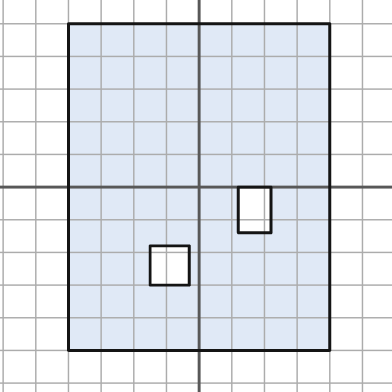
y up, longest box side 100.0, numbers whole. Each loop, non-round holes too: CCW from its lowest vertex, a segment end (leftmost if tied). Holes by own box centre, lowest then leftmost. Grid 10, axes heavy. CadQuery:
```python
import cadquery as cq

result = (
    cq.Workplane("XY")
    .moveTo(-40.0, -50.0)
    .lineTo(40.0, -50.0)
    .lineTo(40.0, 50.0)
    .lineTo(-40.0, 50.0)
    .close()
    .moveTo(-15.0, -30.0)
    .lineTo(-3.0, -30.0)
    .lineTo(-3.0, -18.0)
    .lineTo(-15.0, -18.0)
    .close()
    .moveTo(12.0, -14.0)
    .lineTo(22.0, -14.0)
    .lineTo(22.0, 0.0)
    .lineTo(12.0, 0.0)
    .close()
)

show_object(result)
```